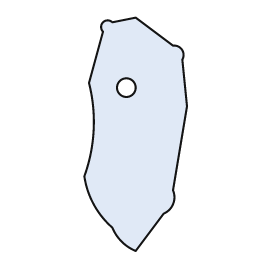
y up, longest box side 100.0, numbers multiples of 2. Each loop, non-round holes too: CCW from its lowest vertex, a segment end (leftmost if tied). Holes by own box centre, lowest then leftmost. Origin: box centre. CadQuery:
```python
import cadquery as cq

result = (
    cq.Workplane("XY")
    .moveTo(0.0, -50.0)
    .lineTo(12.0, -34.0)
    .threePointArc((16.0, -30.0), (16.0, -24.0))
    .lineTo(22.0, 12.0)
    .lineTo(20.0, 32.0)
    .threePointArc((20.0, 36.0), (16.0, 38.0))
    .lineTo(0.0, 50.0)
    .lineTo(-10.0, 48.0)
    .threePointArc((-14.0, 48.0), (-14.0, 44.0))
    .lineTo(-20.0, 22.0)
    .threePointArc((-18.0, 2.0), (-22.0, -18.0))
    .threePointArc((-18.0, -30.0), (-10.0, -40.0))
    .threePointArc((-6.0, -46.0), (0.0, -50.0))
    .close()
    .moveTo(-4.0, 20.0)
    .circle(4.0)
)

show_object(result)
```